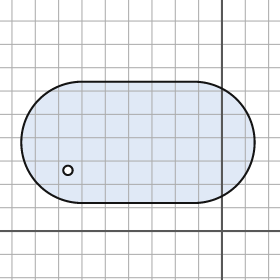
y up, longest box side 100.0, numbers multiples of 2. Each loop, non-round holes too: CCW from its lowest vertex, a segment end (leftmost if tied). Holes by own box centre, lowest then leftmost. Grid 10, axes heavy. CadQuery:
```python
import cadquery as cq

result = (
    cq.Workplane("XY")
    .moveTo(-60.0, 12.0)
    .lineTo(-12.0, 12.0)
    .threePointArc((14.0, 38.0), (-12.0, 64.0))
    .lineTo(-60.0, 64.0)
    .threePointArc((-86.0, 38.0), (-60.0, 12.0))
    .close()
    .moveTo(-66.0, 26.0)
    .circle(2.0)
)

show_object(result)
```